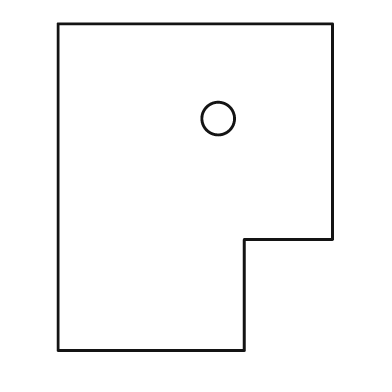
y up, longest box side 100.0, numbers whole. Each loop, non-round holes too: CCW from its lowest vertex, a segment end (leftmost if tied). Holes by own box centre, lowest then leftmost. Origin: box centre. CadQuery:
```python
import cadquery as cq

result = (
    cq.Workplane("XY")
    .moveTo(-42.0, -50.0)
    .lineTo(15.0, -50.0)
    .lineTo(15.0, -16.0)
    .lineTo(42.0, -16.0)
    .lineTo(42.0, 50.0)
    .lineTo(-42.0, 50.0)
    .close()
    .moveTo(7.0, 21.0)
    .circle(5.0)
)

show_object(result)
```